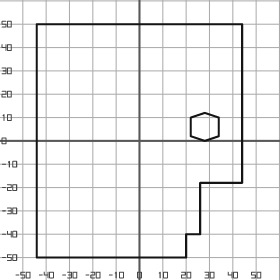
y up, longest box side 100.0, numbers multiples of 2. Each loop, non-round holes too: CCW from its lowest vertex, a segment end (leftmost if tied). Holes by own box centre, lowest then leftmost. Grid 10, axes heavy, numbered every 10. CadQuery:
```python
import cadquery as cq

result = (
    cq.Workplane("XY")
    .moveTo(-44.0, -50.0)
    .lineTo(20.0, -50.0)
    .lineTo(20.0, -40.0)
    .lineTo(26.0, -40.0)
    .lineTo(26.0, -18.0)
    .lineTo(44.0, -18.0)
    .lineTo(44.0, 50.0)
    .lineTo(-44.0, 50.0)
    .close()
    .moveTo(28.0, 0.0)
    .lineTo(34.0, 2.0)
    .lineTo(34.0, 10.0)
    .lineTo(28.0, 12.0)
    .lineTo(22.0, 10.0)
    .lineTo(22.0, 2.0)
    .close()
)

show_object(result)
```